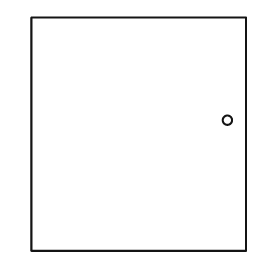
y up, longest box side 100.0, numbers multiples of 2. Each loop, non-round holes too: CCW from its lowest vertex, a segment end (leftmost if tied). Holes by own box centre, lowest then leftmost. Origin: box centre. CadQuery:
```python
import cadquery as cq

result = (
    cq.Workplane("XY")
    .moveTo(-46.0, -50.0)
    .lineTo(46.0, -50.0)
    .lineTo(46.0, 50.0)
    .lineTo(-46.0, 50.0)
    .close()
    .moveTo(38.0, 6.0)
    .circle(2.0)
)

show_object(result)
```